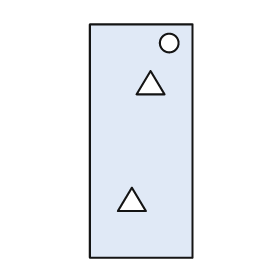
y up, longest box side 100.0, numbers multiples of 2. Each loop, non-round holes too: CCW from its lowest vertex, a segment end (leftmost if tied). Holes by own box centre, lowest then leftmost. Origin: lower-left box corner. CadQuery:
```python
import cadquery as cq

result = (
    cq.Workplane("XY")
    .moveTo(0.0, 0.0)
    .lineTo(44.0, 0.0)
    .lineTo(44.0, 100.0)
    .lineTo(0.0, 100.0)
    .close()
    .moveTo(12.0, 20.0)
    .lineTo(24.0, 20.0)
    .lineTo(18.0, 30.0)
    .close()
    .moveTo(20.0, 70.0)
    .lineTo(32.0, 70.0)
    .lineTo(26.0, 80.0)
    .close()
    .moveTo(34.0, 92.0)
    .circle(4.0)
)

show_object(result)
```